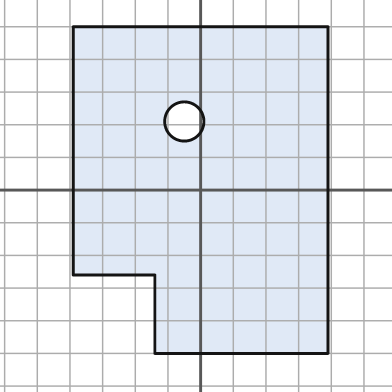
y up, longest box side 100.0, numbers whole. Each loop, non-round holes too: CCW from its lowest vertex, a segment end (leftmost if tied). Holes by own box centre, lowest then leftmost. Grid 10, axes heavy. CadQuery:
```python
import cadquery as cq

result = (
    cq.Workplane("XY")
    .moveTo(-14.0, -50.0)
    .lineTo(39.0, -50.0)
    .lineTo(39.0, 50.0)
    .lineTo(-39.0, 50.0)
    .lineTo(-39.0, -26.0)
    .lineTo(-14.0, -26.0)
    .close()
    .moveTo(-5.0, 21.0)
    .circle(6.0)
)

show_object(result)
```